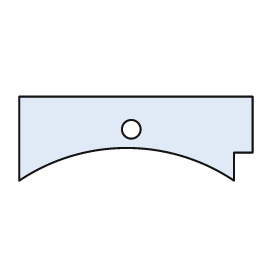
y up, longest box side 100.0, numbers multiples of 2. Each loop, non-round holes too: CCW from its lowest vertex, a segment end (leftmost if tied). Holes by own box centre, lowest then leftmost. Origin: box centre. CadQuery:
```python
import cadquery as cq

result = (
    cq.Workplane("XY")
    .moveTo(-50.0, -18.0)
    .threePointArc((-4.0, -4.0), (42.0, -18.0))
    .lineTo(42.0, -6.0)
    .lineTo(50.0, -6.0)
    .lineTo(50.0, 18.0)
    .lineTo(-50.0, 18.0)
    .close()
    .moveTo(-2.0, 4.0)
    .circle(4.0)
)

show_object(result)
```